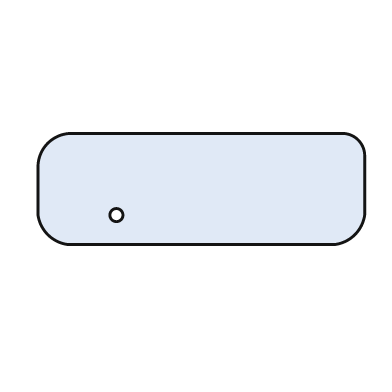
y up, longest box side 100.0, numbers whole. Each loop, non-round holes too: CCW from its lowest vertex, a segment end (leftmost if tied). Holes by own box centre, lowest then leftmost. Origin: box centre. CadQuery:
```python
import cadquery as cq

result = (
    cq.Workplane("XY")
    .moveTo(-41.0, -17.0)
    .lineTo(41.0, -17.0)
    .threePointArc((47.0, -14.0), (50.0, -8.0))
    .lineTo(50.0, 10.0)
    .threePointArc((48.0, 15.0), (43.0, 17.0))
    .lineTo(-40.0, 17.0)
    .threePointArc((-47.0, 14.0), (-50.0, 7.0))
    .lineTo(-50.0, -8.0)
    .threePointArc((-47.0, -14.0), (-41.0, -17.0))
    .close()
    .moveTo(-26.0, -8.0)
    .circle(2.0)
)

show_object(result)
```